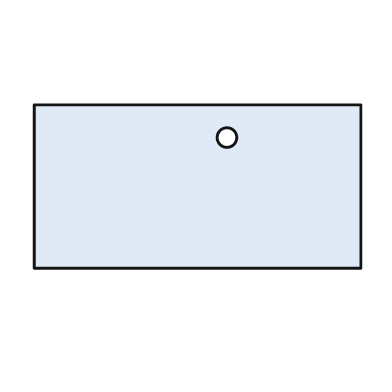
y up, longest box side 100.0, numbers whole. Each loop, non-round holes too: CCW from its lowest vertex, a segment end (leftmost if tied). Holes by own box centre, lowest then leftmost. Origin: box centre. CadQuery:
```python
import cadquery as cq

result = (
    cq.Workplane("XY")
    .moveTo(-50.0, -25.0)
    .lineTo(50.0, -25.0)
    .lineTo(50.0, 25.0)
    .lineTo(-50.0, 25.0)
    .close()
    .moveTo(9.0, 15.0)
    .circle(3.0)
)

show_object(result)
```